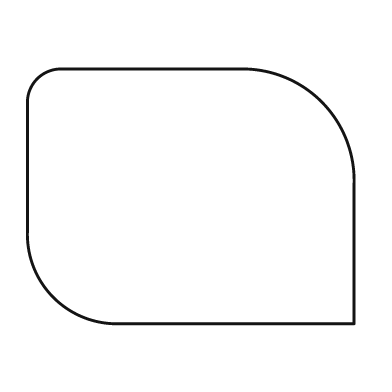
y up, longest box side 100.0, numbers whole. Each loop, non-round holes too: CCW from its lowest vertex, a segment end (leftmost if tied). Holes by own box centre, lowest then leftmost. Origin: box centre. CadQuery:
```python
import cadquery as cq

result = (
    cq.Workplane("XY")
    .moveTo(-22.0, -39.0)
    .lineTo(50.0, -39.0)
    .lineTo(50.0, 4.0)
    .threePointArc((40.0, 29.0), (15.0, 39.0))
    .lineTo(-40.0, 39.0)
    .threePointArc((-47.0, 36.0), (-50.0, 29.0))
    .lineTo(-50.0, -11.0)
    .threePointArc((-42.0, -31.0), (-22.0, -39.0))
    .close()
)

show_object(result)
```